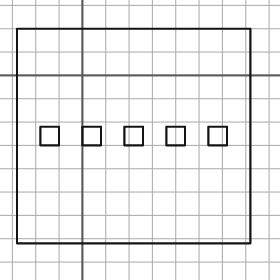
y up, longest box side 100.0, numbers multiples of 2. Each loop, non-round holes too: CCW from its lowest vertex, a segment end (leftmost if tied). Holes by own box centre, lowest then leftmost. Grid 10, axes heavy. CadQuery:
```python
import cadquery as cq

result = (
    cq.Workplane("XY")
    .moveTo(-28.0, -72.0)
    .lineTo(72.0, -72.0)
    .lineTo(72.0, 20.0)
    .lineTo(-28.0, 20.0)
    .close()
    .moveTo(-18.0, -30.0)
    .lineTo(-10.0, -30.0)
    .lineTo(-10.0, -22.0)
    .lineTo(-18.0, -22.0)
    .close()
    .moveTo(0.0, -30.0)
    .lineTo(8.0, -30.0)
    .lineTo(8.0, -22.0)
    .lineTo(0.0, -22.0)
    .close()
    .moveTo(18.0, -30.0)
    .lineTo(26.0, -30.0)
    .lineTo(26.0, -22.0)
    .lineTo(18.0, -22.0)
    .close()
    .moveTo(36.0, -30.0)
    .lineTo(44.0, -30.0)
    .lineTo(44.0, -22.0)
    .lineTo(36.0, -22.0)
    .close()
    .moveTo(54.0, -30.0)
    .lineTo(62.0, -30.0)
    .lineTo(62.0, -22.0)
    .lineTo(54.0, -22.0)
    .close()
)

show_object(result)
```